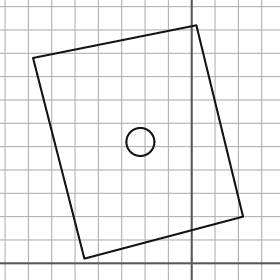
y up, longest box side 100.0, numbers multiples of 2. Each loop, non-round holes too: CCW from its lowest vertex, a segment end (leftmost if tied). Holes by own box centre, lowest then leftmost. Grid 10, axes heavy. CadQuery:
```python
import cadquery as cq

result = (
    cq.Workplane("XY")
    .moveTo(-46.0, 2.0)
    .lineTo(22.0, 20.0)
    .lineTo(2.0, 102.0)
    .lineTo(-68.0, 88.0)
    .close()
    .moveTo(-22.0, 52.0)
    .circle(6.0)
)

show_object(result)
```